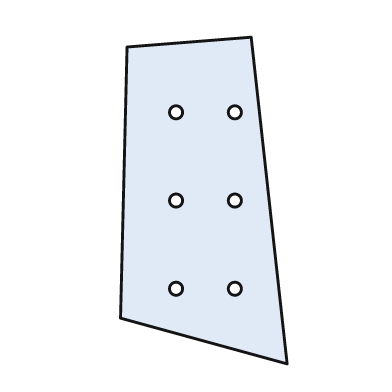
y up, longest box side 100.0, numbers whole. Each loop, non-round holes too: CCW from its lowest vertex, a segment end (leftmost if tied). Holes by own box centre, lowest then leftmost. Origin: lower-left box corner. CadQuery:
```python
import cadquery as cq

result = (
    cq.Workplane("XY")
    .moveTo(51.0, 0.0)
    .lineTo(40.0, 100.0)
    .lineTo(2.0, 97.0)
    .lineTo(0.0, 14.0)
    .close()
    .moveTo(17.0, 23.0)
    .circle(2.0)
    .moveTo(35.0, 23.0)
    .circle(2.0)
    .moveTo(17.0, 50.0)
    .circle(2.0)
    .moveTo(35.0, 50.0)
    .circle(2.0)
    .moveTo(17.0, 77.0)
    .circle(2.0)
    .moveTo(35.0, 77.0)
    .circle(2.0)
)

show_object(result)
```